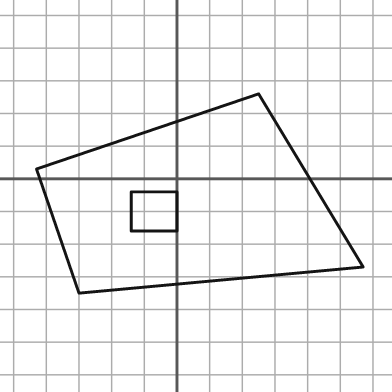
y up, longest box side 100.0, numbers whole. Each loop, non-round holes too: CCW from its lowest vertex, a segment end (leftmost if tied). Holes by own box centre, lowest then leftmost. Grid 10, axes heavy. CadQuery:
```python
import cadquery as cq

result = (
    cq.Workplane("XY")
    .moveTo(-30.0, -35.0)
    .lineTo(57.0, -27.0)
    .lineTo(25.0, 26.0)
    .lineTo(-43.0, 3.0)
    .close()
    .moveTo(-14.0, -16.0)
    .lineTo(0.0, -16.0)
    .lineTo(0.0, -4.0)
    .lineTo(-14.0, -4.0)
    .close()
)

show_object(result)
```